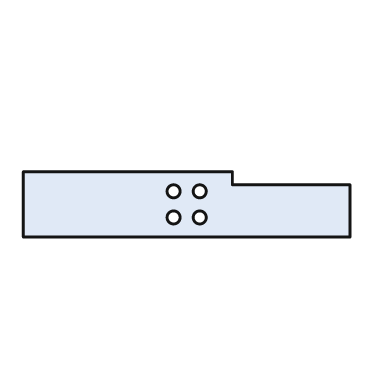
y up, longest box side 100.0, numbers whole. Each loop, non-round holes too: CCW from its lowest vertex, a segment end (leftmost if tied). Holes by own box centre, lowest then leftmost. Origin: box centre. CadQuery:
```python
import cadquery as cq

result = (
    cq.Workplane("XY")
    .moveTo(-50.0, -10.0)
    .lineTo(50.0, -10.0)
    .lineTo(50.0, 6.0)
    .lineTo(14.0, 6.0)
    .lineTo(14.0, 10.0)
    .lineTo(-50.0, 10.0)
    .close()
    .moveTo(-4.0, -4.0)
    .circle(2.0)
    .moveTo(4.0, -4.0)
    .circle(2.0)
    .moveTo(-4.0, 4.0)
    .circle(2.0)
    .moveTo(4.0, 4.0)
    .circle(2.0)
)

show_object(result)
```